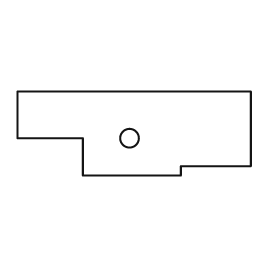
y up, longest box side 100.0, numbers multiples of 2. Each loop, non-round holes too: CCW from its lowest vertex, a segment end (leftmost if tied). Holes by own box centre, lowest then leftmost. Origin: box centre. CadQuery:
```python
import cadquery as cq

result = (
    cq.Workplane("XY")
    .moveTo(-22.0, -18.0)
    .lineTo(20.0, -18.0)
    .lineTo(20.0, -14.0)
    .lineTo(50.0, -14.0)
    .lineTo(50.0, 18.0)
    .lineTo(-50.0, 18.0)
    .lineTo(-50.0, -2.0)
    .lineTo(-22.0, -2.0)
    .close()
    .moveTo(-2.0, -2.0)
    .circle(4.0)
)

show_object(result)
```